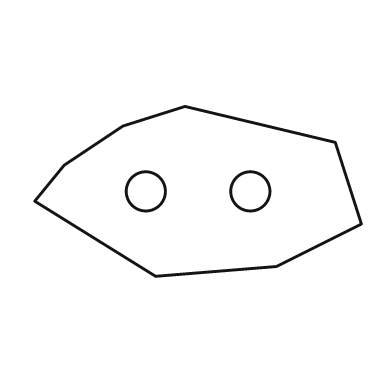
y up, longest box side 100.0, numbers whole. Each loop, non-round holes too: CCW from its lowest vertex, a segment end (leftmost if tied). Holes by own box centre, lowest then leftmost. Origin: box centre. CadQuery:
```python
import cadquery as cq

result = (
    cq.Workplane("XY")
    .moveTo(-13.0, -26.0)
    .lineTo(24.0, -23.0)
    .lineTo(50.0, -10.0)
    .lineTo(42.0, 15.0)
    .lineTo(-4.0, 26.0)
    .lineTo(-23.0, 20.0)
    .lineTo(-41.0, 8.0)
    .lineTo(-50.0, -3.0)
    .close()
    .moveTo(-16.0, 0.0)
    .circle(6.0)
    .moveTo(16.0, 0.0)
    .circle(6.0)
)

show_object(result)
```